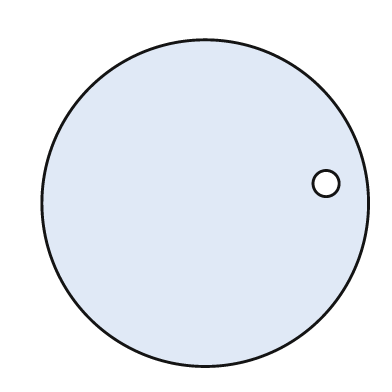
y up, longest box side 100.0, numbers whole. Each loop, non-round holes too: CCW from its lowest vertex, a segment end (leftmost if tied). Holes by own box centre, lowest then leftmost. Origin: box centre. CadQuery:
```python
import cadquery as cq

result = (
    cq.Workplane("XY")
    .moveTo(0.0, 0.0)
    .circle(50.0)
    .moveTo(37.0, 6.0)
    .circle(4.0)
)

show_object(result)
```